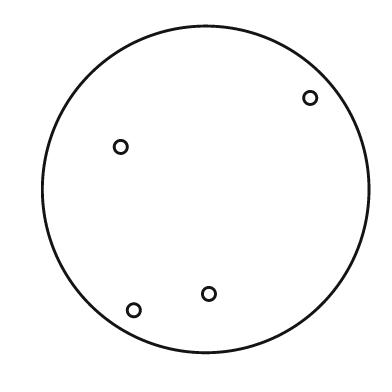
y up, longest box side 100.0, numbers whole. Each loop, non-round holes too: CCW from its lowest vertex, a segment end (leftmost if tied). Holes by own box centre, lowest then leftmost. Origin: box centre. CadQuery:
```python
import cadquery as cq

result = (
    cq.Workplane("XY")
    .moveTo(0.0, 0.0)
    .circle(50.0)
    .moveTo(-22.0, -37.0)
    .circle(2.0)
    .moveTo(1.0, -32.0)
    .circle(2.0)
    .moveTo(-26.0, 13.0)
    .circle(2.0)
    .moveTo(32.0, 28.0)
    .circle(2.0)
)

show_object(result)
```